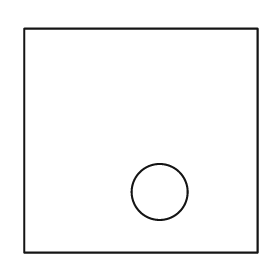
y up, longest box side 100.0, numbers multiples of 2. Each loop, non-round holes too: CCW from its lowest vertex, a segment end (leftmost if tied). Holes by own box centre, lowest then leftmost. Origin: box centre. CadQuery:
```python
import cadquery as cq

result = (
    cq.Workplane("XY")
    .moveTo(-50.0, -48.0)
    .lineTo(50.0, -48.0)
    .lineTo(50.0, 48.0)
    .lineTo(-50.0, 48.0)
    .close()
    .moveTo(8.0, -22.0)
    .circle(12.0)
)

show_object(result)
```